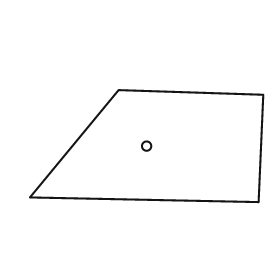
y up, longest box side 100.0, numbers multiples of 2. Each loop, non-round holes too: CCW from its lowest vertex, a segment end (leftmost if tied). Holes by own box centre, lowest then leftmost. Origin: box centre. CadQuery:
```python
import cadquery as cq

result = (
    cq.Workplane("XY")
    .moveTo(48.0, -24.0)
    .lineTo(50.0, 22.0)
    .lineTo(-12.0, 24.0)
    .lineTo(-50.0, -22.0)
    .close()
    .moveTo(0.0, 0.0)
    .circle(2.0)
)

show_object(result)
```